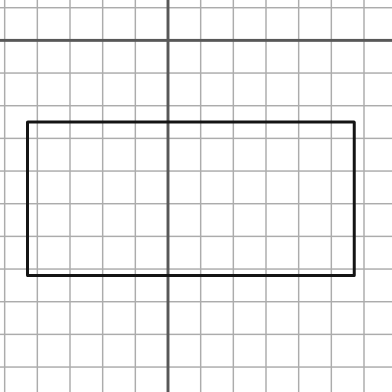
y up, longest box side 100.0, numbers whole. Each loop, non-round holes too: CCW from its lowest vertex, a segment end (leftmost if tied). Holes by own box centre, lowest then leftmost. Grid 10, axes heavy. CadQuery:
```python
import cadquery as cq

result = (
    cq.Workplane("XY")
    .moveTo(-43.0, -72.0)
    .lineTo(57.0, -72.0)
    .lineTo(57.0, -25.0)
    .lineTo(-43.0, -25.0)
    .close()
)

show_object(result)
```